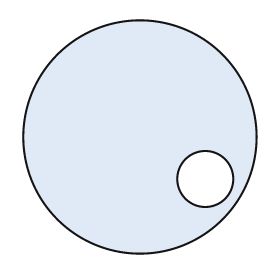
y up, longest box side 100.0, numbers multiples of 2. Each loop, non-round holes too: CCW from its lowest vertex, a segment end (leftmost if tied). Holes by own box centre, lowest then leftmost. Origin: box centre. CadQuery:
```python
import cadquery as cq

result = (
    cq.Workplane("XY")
    .moveTo(0.0, 0.0)
    .circle(50.0)
    .moveTo(28.0, -18.0)
    .circle(12.0)
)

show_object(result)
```